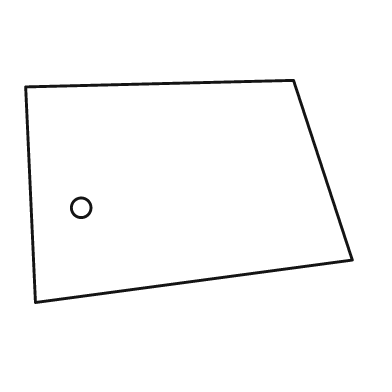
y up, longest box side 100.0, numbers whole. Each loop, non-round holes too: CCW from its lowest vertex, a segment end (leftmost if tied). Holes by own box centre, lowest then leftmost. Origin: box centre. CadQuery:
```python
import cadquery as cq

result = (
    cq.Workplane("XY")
    .moveTo(-47.0, -34.0)
    .lineTo(50.0, -21.0)
    .lineTo(32.0, 34.0)
    .lineTo(-50.0, 32.0)
    .close()
    .moveTo(-33.0, -5.0)
    .circle(3.0)
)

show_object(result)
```